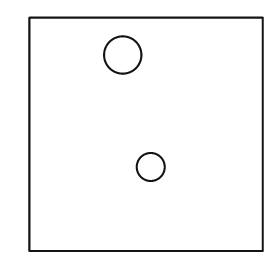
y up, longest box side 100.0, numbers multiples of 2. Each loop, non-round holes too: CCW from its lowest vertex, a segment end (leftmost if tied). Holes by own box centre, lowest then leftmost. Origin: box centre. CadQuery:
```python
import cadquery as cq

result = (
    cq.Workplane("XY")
    .moveTo(-50.0, -50.0)
    .lineTo(50.0, -50.0)
    .lineTo(50.0, 50.0)
    .lineTo(-50.0, 50.0)
    .close()
    .moveTo(2.0, -14.0)
    .circle(6.0)
    .moveTo(-10.0, 34.0)
    .circle(8.0)
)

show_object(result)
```